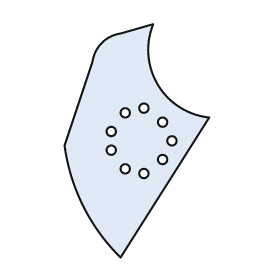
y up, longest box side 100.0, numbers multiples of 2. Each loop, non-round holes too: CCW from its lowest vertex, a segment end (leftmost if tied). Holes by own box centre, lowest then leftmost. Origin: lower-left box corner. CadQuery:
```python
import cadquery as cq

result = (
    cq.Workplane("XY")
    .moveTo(24.0, 0.0)
    .lineTo(62.0, 60.0)
    .threePointArc((40.0, 74.0), (38.0, 100.0))
    .lineTo(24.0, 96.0)
    .threePointArc((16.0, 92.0), (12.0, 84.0))
    .lineTo(0.0, 48.0)
    .threePointArc((8.0, 22.0), (24.0, 0.0))
    .close()
    .moveTo(34.0, 36.0)
    .circle(2.0)
    .moveTo(26.0, 38.0)
    .circle(2.0)
    .moveTo(42.0, 42.0)
    .circle(2.0)
    .moveTo(20.0, 46.0)
    .circle(2.0)
    .moveTo(46.0, 50.0)
    .circle(2.0)
    .moveTo(20.0, 54.0)
    .circle(2.0)
    .moveTo(42.0, 58.0)
    .circle(2.0)
    .moveTo(26.0, 62.0)
    .circle(2.0)
    .moveTo(34.0, 64.0)
    .circle(2.0)
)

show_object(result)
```